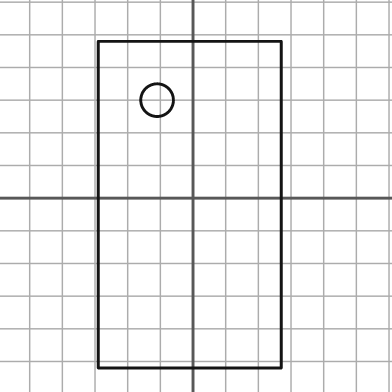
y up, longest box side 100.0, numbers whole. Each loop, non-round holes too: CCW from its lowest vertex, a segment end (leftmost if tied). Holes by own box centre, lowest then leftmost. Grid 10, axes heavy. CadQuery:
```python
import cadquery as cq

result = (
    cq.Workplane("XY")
    .moveTo(-29.0, -52.0)
    .lineTo(27.0, -52.0)
    .lineTo(27.0, 48.0)
    .lineTo(-29.0, 48.0)
    .close()
    .moveTo(-11.0, 30.0)
    .circle(5.0)
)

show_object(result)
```